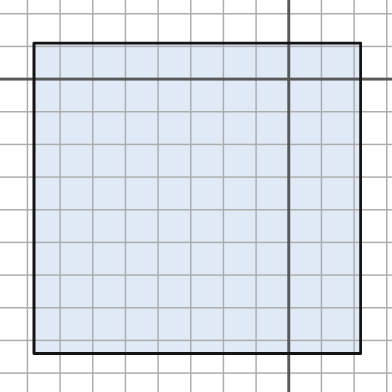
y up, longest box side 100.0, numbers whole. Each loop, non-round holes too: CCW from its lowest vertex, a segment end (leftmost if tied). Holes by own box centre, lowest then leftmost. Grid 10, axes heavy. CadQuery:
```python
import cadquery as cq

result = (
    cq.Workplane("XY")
    .moveTo(-78.0, -84.0)
    .lineTo(22.0, -84.0)
    .lineTo(22.0, 11.0)
    .lineTo(-78.0, 11.0)
    .close()
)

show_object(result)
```